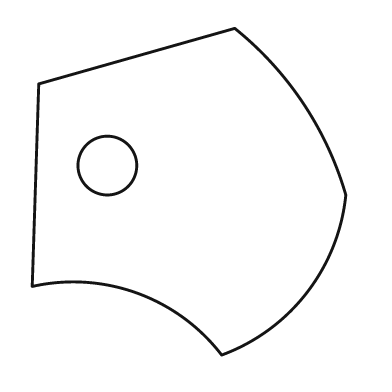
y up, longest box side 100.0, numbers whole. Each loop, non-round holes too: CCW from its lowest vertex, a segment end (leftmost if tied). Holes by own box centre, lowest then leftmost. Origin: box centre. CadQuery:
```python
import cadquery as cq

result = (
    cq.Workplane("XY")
    .moveTo(10.0, -50.0)
    .threePointArc((36.0, -31.0), (48.0, -1.0))
    .threePointArc((35.0, 27.0), (14.0, 50.0))
    .lineTo(-46.0, 33.0)
    .lineTo(-48.0, -29.0)
    .threePointArc((-16.0, -31.0), (10.0, -50.0))
    .close()
    .moveTo(-25.0, 8.0)
    .circle(9.0)
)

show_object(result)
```